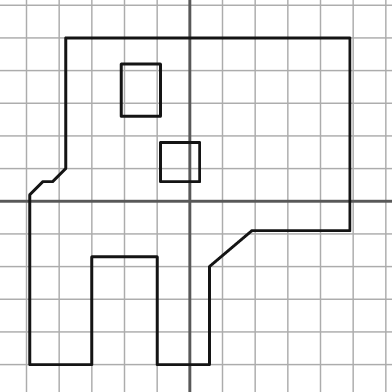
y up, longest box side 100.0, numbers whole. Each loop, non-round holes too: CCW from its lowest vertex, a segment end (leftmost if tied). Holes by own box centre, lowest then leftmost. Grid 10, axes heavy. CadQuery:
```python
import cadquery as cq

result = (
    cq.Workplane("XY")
    .moveTo(-49.0, -50.0)
    .lineTo(-30.0, -50.0)
    .lineTo(-30.0, -17.0)
    .lineTo(-10.0, -17.0)
    .lineTo(-10.0, -50.0)
    .lineTo(6.0, -50.0)
    .lineTo(6.0, -20.0)
    .lineTo(19.0, -9.0)
    .lineTo(49.0, -9.0)
    .lineTo(49.0, 50.0)
    .lineTo(-38.0, 50.0)
    .lineTo(-38.0, 10.0)
    .lineTo(-42.0, 6.0)
    .lineTo(-45.0, 6.0)
    .lineTo(-49.0, 2.0)
    .close()
    .moveTo(-9.0, 6.0)
    .lineTo(3.0, 6.0)
    .lineTo(3.0, 18.0)
    .lineTo(-9.0, 18.0)
    .close()
    .moveTo(-21.0, 26.0)
    .lineTo(-9.0, 26.0)
    .lineTo(-9.0, 42.0)
    .lineTo(-21.0, 42.0)
    .close()
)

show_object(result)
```